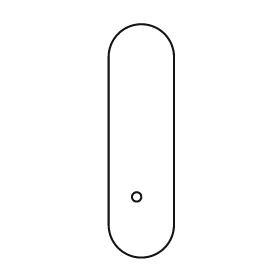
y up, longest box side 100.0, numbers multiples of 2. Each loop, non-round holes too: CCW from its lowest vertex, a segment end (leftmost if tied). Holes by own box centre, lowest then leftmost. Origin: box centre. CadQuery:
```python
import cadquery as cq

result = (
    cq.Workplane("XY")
    .moveTo(-14.0, -36.0)
    .threePointArc((0.0, -50.0), (14.0, -36.0))
    .lineTo(14.0, 36.0)
    .threePointArc((0.0, 50.0), (-14.0, 36.0))
    .close()
    .moveTo(-2.0, -24.0)
    .circle(2.0)
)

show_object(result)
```